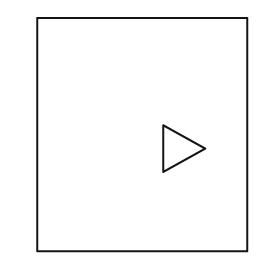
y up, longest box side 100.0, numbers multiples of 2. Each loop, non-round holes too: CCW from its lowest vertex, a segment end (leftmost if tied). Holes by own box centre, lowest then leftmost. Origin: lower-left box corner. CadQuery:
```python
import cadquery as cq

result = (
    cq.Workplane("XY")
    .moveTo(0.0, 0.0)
    .lineTo(90.0, 0.0)
    .lineTo(90.0, 100.0)
    .lineTo(0.0, 100.0)
    .close()
    .moveTo(54.0, 34.0)
    .lineTo(72.0, 44.0)
    .lineTo(54.0, 54.0)
    .close()
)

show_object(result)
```